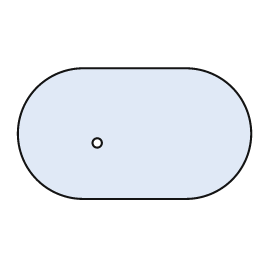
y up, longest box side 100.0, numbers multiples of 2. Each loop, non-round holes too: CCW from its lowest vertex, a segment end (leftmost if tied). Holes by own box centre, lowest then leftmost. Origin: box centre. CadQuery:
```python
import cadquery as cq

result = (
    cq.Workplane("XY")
    .moveTo(-22.0, -28.0)
    .lineTo(22.0, -28.0)
    .threePointArc((50.0, 0.0), (22.0, 28.0))
    .lineTo(-22.0, 28.0)
    .threePointArc((-50.0, 0.0), (-22.0, -28.0))
    .close()
    .moveTo(-16.0, -4.0)
    .circle(2.0)
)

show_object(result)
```